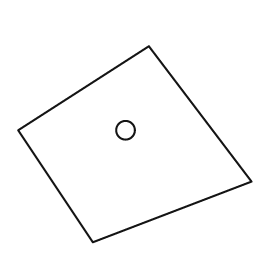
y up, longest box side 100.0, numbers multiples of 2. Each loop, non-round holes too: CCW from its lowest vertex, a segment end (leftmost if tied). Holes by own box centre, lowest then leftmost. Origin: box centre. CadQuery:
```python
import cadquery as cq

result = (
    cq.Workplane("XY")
    .moveTo(-18.0, -42.0)
    .lineTo(50.0, -16.0)
    .lineTo(6.0, 42.0)
    .lineTo(-50.0, 6.0)
    .close()
    .moveTo(-4.0, 6.0)
    .circle(4.0)
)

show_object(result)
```